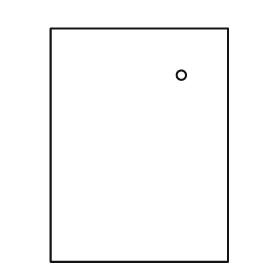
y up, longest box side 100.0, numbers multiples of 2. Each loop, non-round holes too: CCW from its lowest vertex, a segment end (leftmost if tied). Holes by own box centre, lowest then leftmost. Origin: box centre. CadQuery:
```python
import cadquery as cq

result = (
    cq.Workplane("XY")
    .moveTo(-38.0, -50.0)
    .lineTo(38.0, -50.0)
    .lineTo(38.0, 50.0)
    .lineTo(-38.0, 50.0)
    .close()
    .moveTo(18.0, 30.0)
    .circle(2.0)
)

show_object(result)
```